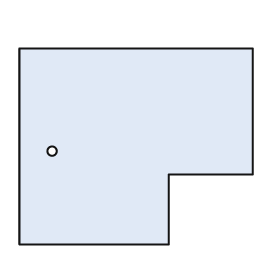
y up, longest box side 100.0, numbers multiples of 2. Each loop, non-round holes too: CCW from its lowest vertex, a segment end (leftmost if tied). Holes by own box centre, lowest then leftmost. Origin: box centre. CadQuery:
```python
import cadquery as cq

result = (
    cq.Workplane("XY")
    .moveTo(-50.0, -42.0)
    .lineTo(14.0, -42.0)
    .lineTo(14.0, -12.0)
    .lineTo(50.0, -12.0)
    .lineTo(50.0, 42.0)
    .lineTo(-50.0, 42.0)
    .close()
    .moveTo(-36.0, -2.0)
    .circle(2.0)
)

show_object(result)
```